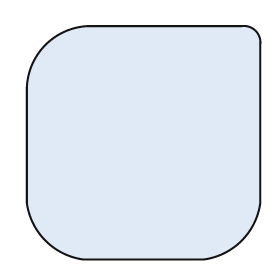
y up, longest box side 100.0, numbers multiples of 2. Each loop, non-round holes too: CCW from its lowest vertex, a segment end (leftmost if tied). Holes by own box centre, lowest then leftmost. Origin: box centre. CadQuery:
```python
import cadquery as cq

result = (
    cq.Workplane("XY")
    .moveTo(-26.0, -50.0)
    .lineTo(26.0, -50.0)
    .threePointArc((42.0, -42.0), (50.0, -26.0))
    .lineTo(50.0, 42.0)
    .threePointArc((48.0, 48.0), (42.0, 50.0))
    .lineTo(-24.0, 50.0)
    .threePointArc((-42.0, 42.0), (-50.0, 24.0))
    .lineTo(-50.0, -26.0)
    .threePointArc((-42.0, -42.0), (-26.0, -50.0))
    .close()
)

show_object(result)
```